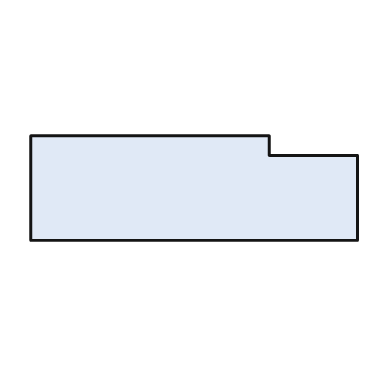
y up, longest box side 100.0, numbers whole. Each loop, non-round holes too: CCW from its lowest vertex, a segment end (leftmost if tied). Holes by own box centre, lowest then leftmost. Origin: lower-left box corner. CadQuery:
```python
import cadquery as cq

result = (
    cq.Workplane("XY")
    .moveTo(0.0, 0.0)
    .lineTo(100.0, 0.0)
    .lineTo(100.0, 26.0)
    .lineTo(73.0, 26.0)
    .lineTo(73.0, 32.0)
    .lineTo(0.0, 32.0)
    .close()
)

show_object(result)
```